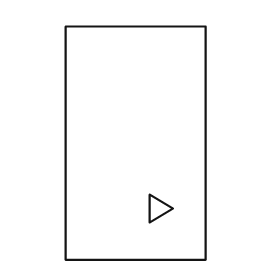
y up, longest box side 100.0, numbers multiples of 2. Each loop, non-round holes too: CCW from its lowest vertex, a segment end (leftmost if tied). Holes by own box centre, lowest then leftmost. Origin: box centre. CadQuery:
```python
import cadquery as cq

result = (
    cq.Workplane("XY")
    .moveTo(-30.0, -50.0)
    .lineTo(30.0, -50.0)
    .lineTo(30.0, 50.0)
    .lineTo(-30.0, 50.0)
    .close()
    .moveTo(6.0, -34.0)
    .lineTo(16.0, -28.0)
    .lineTo(6.0, -22.0)
    .close()
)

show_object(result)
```